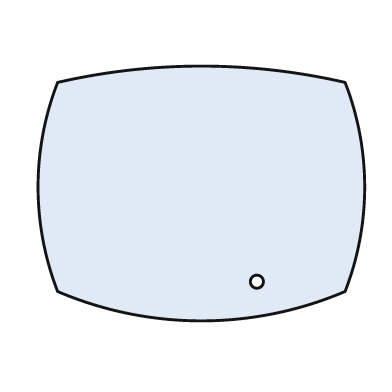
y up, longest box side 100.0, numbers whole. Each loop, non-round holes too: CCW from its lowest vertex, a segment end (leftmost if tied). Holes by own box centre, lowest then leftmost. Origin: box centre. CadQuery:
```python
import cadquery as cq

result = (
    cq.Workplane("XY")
    .moveTo(-44.0, -30.0)
    .threePointArc((0.0, -39.0), (44.0, -30.0))
    .threePointArc((50.0, 2.0), (44.0, 34.0))
    .threePointArc((0.0, 39.0), (-44.0, 34.0))
    .threePointArc((-50.0, 2.0), (-44.0, -30.0))
    .close()
    .moveTo(17.0, -27.0)
    .circle(2.0)
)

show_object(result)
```